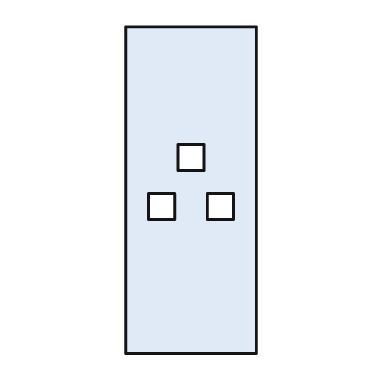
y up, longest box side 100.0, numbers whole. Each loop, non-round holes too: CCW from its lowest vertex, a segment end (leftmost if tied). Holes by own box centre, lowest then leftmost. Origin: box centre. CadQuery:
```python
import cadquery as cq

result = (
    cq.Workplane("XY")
    .moveTo(-20.0, -50.0)
    .lineTo(20.0, -50.0)
    .lineTo(20.0, 50.0)
    .lineTo(-20.0, 50.0)
    .close()
    .moveTo(-13.0, -9.0)
    .lineTo(-5.0, -9.0)
    .lineTo(-5.0, -1.0)
    .lineTo(-13.0, -1.0)
    .close()
    .moveTo(5.0, -9.0)
    .lineTo(13.0, -9.0)
    .lineTo(13.0, -1.0)
    .lineTo(5.0, -1.0)
    .close()
    .moveTo(-4.0, 6.0)
    .lineTo(4.0, 6.0)
    .lineTo(4.0, 14.0)
    .lineTo(-4.0, 14.0)
    .close()
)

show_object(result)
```